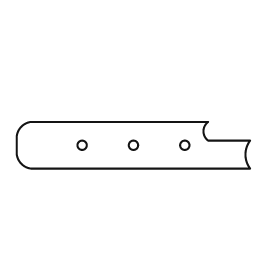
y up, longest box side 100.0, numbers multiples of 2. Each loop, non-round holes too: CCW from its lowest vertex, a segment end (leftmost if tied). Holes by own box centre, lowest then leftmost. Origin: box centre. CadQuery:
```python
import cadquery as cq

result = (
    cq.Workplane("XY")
    .moveTo(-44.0, -10.0)
    .lineTo(50.0, -10.0)
    .threePointArc((48.0, -4.0), (50.0, 2.0))
    .lineTo(32.0, 2.0)
    .threePointArc((30.0, 6.0), (32.0, 10.0))
    .lineTo(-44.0, 10.0)
    .threePointArc((-48.0, 8.0), (-50.0, 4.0))
    .lineTo(-50.0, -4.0)
    .threePointArc((-48.0, -8.0), (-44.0, -10.0))
    .close()
    .moveTo(-22.0, 0.0)
    .circle(2.0)
    .moveTo(0.0, 0.0)
    .circle(2.0)
    .moveTo(22.0, 0.0)
    .circle(2.0)
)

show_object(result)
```